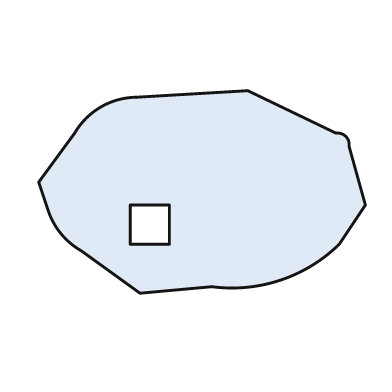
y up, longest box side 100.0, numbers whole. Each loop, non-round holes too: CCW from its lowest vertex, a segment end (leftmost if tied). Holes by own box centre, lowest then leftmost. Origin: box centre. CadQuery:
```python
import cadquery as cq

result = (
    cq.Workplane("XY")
    .moveTo(-19.0, -31.0)
    .lineTo(3.0, -29.0)
    .threePointArc((24.0, -27.0), (42.0, -16.0))
    .lineTo(50.0, -4.0)
    .lineTo(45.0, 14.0)
    .threePointArc((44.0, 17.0), (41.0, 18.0))
    .lineTo(14.0, 31.0)
    .lineTo(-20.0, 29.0)
    .threePointArc((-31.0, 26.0), (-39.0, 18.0))
    .lineTo(-50.0, 3.0)
    .lineTo(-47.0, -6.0)
    .threePointArc((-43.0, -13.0), (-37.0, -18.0))
    .close()
    .moveTo(-22.0, -16.0)
    .lineTo(-10.0, -16.0)
    .lineTo(-10.0, -4.0)
    .lineTo(-22.0, -4.0)
    .close()
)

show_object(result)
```